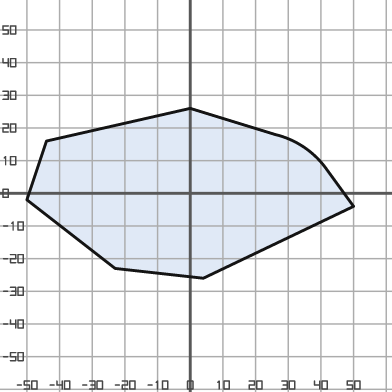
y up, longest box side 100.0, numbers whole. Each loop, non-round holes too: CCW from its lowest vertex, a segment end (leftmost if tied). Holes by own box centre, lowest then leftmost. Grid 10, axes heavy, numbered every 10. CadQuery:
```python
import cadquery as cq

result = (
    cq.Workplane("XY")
    .moveTo(4.0, -26.0)
    .lineTo(50.0, -4.0)
    .lineTo(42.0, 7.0)
    .threePointArc((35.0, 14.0), (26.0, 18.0))
    .lineTo(0.0, 26.0)
    .lineTo(-44.0, 16.0)
    .lineTo(-50.0, -2.0)
    .lineTo(-23.0, -23.0)
    .close()
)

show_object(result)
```